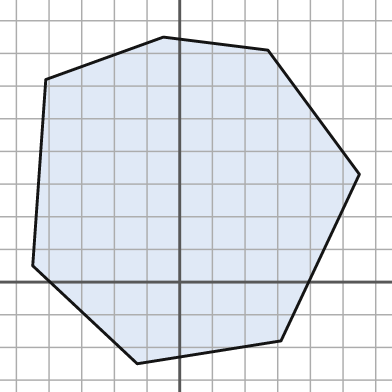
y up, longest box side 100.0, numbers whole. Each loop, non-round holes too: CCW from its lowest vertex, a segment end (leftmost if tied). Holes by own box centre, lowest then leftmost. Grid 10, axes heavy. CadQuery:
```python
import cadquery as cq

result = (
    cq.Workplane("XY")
    .moveTo(-13.0, -25.0)
    .lineTo(31.0, -18.0)
    .lineTo(55.0, 33.0)
    .lineTo(27.0, 71.0)
    .lineTo(-5.0, 75.0)
    .lineTo(-41.0, 62.0)
    .lineTo(-45.0, 5.0)
    .close()
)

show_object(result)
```